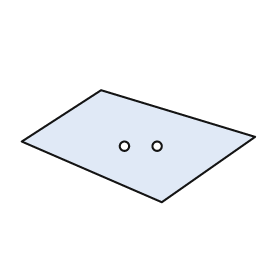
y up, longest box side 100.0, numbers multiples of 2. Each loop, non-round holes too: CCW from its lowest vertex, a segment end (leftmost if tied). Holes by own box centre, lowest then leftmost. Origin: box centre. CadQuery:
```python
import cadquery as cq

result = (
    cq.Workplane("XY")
    .moveTo(10.0, -24.0)
    .lineTo(50.0, 4.0)
    .lineTo(-16.0, 24.0)
    .lineTo(-50.0, 2.0)
    .close()
    .moveTo(-6.0, 0.0)
    .circle(2.0)
    .moveTo(8.0, 0.0)
    .circle(2.0)
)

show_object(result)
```